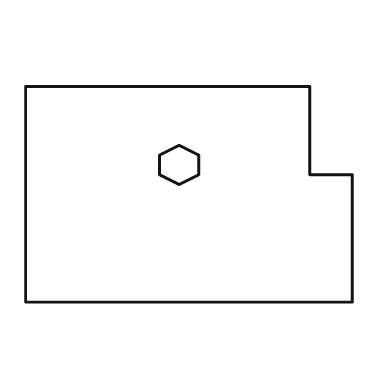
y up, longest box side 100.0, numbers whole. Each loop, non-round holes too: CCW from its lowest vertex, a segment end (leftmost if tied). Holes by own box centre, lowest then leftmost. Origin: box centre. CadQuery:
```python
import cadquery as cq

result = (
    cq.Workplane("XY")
    .moveTo(-50.0, -33.0)
    .lineTo(50.0, -33.0)
    .lineTo(50.0, 6.0)
    .lineTo(37.0, 6.0)
    .lineTo(37.0, 33.0)
    .lineTo(-50.0, 33.0)
    .close()
    .moveTo(-3.0, 3.0)
    .lineTo(3.0, 6.0)
    .lineTo(3.0, 12.0)
    .lineTo(-3.0, 15.0)
    .lineTo(-9.0, 12.0)
    .lineTo(-9.0, 6.0)
    .close()
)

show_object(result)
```